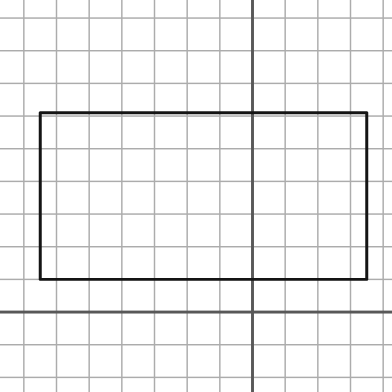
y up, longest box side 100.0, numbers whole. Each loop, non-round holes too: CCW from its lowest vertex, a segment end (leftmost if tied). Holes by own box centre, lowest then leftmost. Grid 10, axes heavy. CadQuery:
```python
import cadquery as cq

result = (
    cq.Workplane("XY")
    .moveTo(-65.0, 10.0)
    .lineTo(35.0, 10.0)
    .lineTo(35.0, 61.0)
    .lineTo(-65.0, 61.0)
    .close()
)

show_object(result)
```